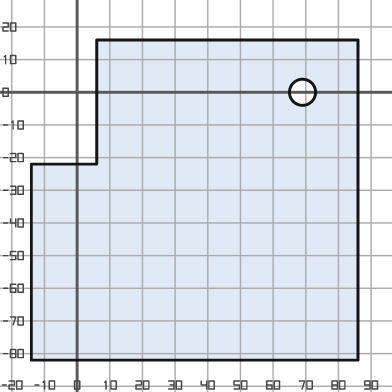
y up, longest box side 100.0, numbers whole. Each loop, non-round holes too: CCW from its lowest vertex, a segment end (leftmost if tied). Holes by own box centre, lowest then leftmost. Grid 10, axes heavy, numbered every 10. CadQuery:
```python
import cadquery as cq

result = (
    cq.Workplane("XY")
    .moveTo(-14.0, -82.0)
    .lineTo(86.0, -82.0)
    .lineTo(86.0, 16.0)
    .lineTo(6.0, 16.0)
    .lineTo(6.0, -22.0)
    .lineTo(-14.0, -22.0)
    .close()
    .moveTo(69.0, 0.0)
    .circle(4.0)
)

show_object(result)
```